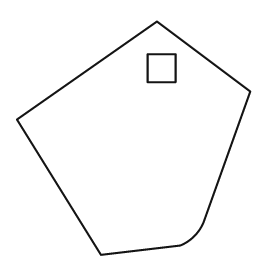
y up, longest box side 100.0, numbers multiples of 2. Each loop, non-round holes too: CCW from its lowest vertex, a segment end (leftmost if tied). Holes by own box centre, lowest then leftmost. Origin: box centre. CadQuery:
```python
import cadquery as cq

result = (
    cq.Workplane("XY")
    .moveTo(-14.0, -50.0)
    .lineTo(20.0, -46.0)
    .threePointArc((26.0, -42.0), (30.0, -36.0))
    .lineTo(50.0, 20.0)
    .lineTo(10.0, 50.0)
    .lineTo(-50.0, 8.0)
    .close()
    .moveTo(6.0, 24.0)
    .lineTo(18.0, 24.0)
    .lineTo(18.0, 36.0)
    .lineTo(6.0, 36.0)
    .close()
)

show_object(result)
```